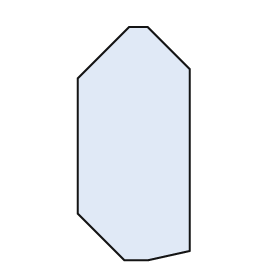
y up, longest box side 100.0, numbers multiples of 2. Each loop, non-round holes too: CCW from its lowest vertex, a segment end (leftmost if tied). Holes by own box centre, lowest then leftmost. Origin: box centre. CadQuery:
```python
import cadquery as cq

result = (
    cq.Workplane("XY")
    .moveTo(-4.0, -50.0)
    .lineTo(6.0, -50.0)
    .lineTo(24.0, -46.0)
    .lineTo(24.0, 32.0)
    .lineTo(6.0, 50.0)
    .lineTo(-2.0, 50.0)
    .lineTo(-24.0, 28.0)
    .lineTo(-24.0, -30.0)
    .close()
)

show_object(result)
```